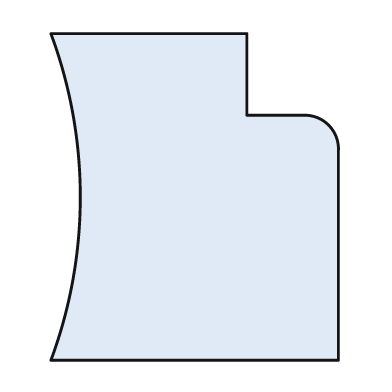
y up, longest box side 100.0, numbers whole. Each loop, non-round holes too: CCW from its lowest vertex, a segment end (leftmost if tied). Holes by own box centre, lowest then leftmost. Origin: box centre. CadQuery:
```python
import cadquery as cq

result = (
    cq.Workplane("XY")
    .moveTo(-44.0, -50.0)
    .lineTo(44.0, -50.0)
    .lineTo(44.0, 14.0)
    .threePointArc((41.0, 22.0), (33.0, 25.0))
    .lineTo(16.0, 25.0)
    .lineTo(16.0, 50.0)
    .lineTo(-44.0, 50.0)
    .threePointArc((-35.0, 0.0), (-44.0, -50.0))
    .close()
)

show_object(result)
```